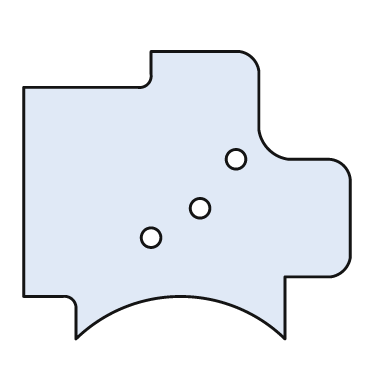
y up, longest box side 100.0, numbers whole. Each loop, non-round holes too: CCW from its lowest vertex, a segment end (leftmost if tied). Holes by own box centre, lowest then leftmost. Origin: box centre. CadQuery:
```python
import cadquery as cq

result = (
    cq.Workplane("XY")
    .moveTo(-34.0, -44.0)
    .threePointArc((-2.0, -31.0), (30.0, -44.0))
    .lineTo(30.0, -25.0)
    .lineTo(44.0, -25.0)
    .threePointArc((48.0, -23.0), (50.0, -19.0))
    .lineTo(50.0, 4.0)
    .threePointArc((48.0, 9.0), (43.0, 11.0))
    .lineTo(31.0, 11.0)
    .threePointArc((25.0, 14.0), (22.0, 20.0))
    .lineTo(22.0, 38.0)
    .threePointArc((20.0, 42.0), (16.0, 44.0))
    .lineTo(-11.0, 44.0)
    .lineTo(-11.0, 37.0)
    .threePointArc((-12.0, 34.0), (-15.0, 33.0))
    .lineTo(-50.0, 33.0)
    .lineTo(-50.0, -31.0)
    .lineTo(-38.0, -31.0)
    .threePointArc((-35.0, -32.0), (-34.0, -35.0))
    .close()
    .moveTo(-11.0, -13.0)
    .circle(3.0)
    .moveTo(4.0, -4.0)
    .circle(3.0)
    .moveTo(15.0, 11.0)
    .circle(3.0)
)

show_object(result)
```